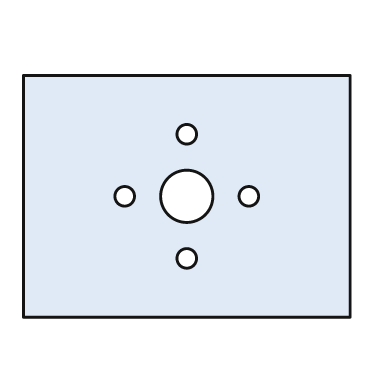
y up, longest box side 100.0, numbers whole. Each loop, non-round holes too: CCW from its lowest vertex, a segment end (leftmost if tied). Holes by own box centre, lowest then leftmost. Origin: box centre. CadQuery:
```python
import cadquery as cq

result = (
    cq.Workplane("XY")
    .moveTo(-50.0, -37.0)
    .lineTo(50.0, -37.0)
    .lineTo(50.0, 37.0)
    .lineTo(-50.0, 37.0)
    .close()
    .moveTo(0.0, -19.0)
    .circle(3.0)
    .moveTo(-19.0, 0.0)
    .circle(3.0)
    .moveTo(0.0, 0.0)
    .circle(8.0)
    .moveTo(19.0, 0.0)
    .circle(3.0)
    .moveTo(0.0, 19.0)
    .circle(3.0)
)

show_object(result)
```